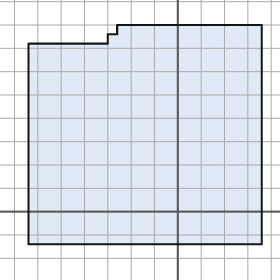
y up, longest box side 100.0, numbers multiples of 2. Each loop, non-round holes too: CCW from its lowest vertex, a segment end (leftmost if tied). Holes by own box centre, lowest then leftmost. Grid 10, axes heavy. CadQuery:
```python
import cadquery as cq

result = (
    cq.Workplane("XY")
    .moveTo(-64.0, -14.0)
    .lineTo(36.0, -14.0)
    .lineTo(36.0, 80.0)
    .lineTo(-26.0, 80.0)
    .lineTo(-26.0, 76.0)
    .lineTo(-30.0, 76.0)
    .lineTo(-30.0, 72.0)
    .lineTo(-64.0, 72.0)
    .close()
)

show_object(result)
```